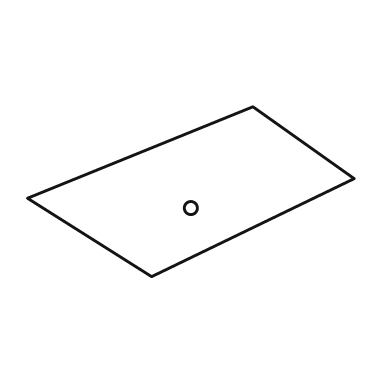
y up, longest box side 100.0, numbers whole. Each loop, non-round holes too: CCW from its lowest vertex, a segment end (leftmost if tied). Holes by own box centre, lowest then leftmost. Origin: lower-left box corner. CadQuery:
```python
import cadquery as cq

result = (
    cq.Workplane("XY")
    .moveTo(38.0, 0.0)
    .lineTo(100.0, 30.0)
    .lineTo(69.0, 52.0)
    .lineTo(0.0, 24.0)
    .close()
    .moveTo(50.0, 21.0)
    .circle(2.0)
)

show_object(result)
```